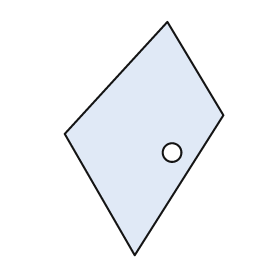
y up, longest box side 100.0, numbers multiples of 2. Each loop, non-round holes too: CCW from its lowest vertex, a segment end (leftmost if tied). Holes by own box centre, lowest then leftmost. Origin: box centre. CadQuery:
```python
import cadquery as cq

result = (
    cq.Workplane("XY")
    .moveTo(-4.0, -50.0)
    .lineTo(34.0, 10.0)
    .lineTo(10.0, 50.0)
    .lineTo(-34.0, 2.0)
    .close()
    .moveTo(12.0, -6.0)
    .circle(4.0)
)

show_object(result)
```